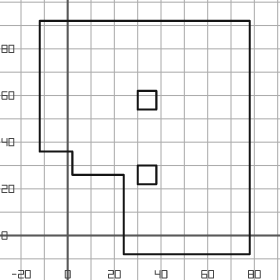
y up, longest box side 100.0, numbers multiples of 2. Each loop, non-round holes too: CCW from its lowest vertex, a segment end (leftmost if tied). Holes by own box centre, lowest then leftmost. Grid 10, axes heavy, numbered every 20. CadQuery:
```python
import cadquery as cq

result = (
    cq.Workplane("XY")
    .moveTo(24.0, -8.0)
    .lineTo(78.0, -8.0)
    .lineTo(78.0, 92.0)
    .lineTo(-12.0, 92.0)
    .lineTo(-12.0, 36.0)
    .lineTo(2.0, 36.0)
    .lineTo(2.0, 26.0)
    .lineTo(24.0, 26.0)
    .close()
    .moveTo(30.0, 22.0)
    .lineTo(38.0, 22.0)
    .lineTo(38.0, 30.0)
    .lineTo(30.0, 30.0)
    .close()
    .moveTo(30.0, 54.0)
    .lineTo(38.0, 54.0)
    .lineTo(38.0, 62.0)
    .lineTo(30.0, 62.0)
    .close()
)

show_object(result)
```